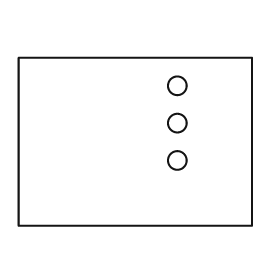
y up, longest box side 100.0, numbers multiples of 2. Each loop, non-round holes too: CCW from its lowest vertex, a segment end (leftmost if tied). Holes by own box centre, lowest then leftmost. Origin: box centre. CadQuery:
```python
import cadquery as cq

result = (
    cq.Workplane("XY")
    .moveTo(-50.0, -36.0)
    .lineTo(50.0, -36.0)
    .lineTo(50.0, 36.0)
    .lineTo(-50.0, 36.0)
    .close()
    .moveTo(18.0, -8.0)
    .circle(4.0)
    .moveTo(18.0, 8.0)
    .circle(4.0)
    .moveTo(18.0, 24.0)
    .circle(4.0)
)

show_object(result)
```